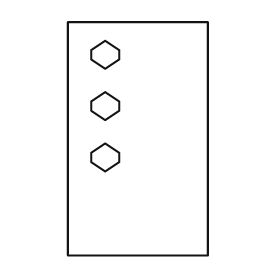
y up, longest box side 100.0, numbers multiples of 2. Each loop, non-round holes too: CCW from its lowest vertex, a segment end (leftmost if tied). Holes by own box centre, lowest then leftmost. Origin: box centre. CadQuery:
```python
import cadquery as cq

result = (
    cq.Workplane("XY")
    .moveTo(-30.0, -50.0)
    .lineTo(30.0, -50.0)
    .lineTo(30.0, 50.0)
    .lineTo(-30.0, 50.0)
    .close()
    .moveTo(-14.0, -14.0)
    .lineTo(-8.0, -10.0)
    .lineTo(-8.0, -6.0)
    .lineTo(-14.0, -2.0)
    .lineTo(-20.0, -6.0)
    .lineTo(-20.0, -10.0)
    .close()
    .moveTo(-14.0, 8.0)
    .lineTo(-8.0, 12.0)
    .lineTo(-8.0, 16.0)
    .lineTo(-14.0, 20.0)
    .lineTo(-20.0, 16.0)
    .lineTo(-20.0, 12.0)
    .close()
    .moveTo(-14.0, 30.0)
    .lineTo(-8.0, 34.0)
    .lineTo(-8.0, 38.0)
    .lineTo(-14.0, 42.0)
    .lineTo(-20.0, 38.0)
    .lineTo(-20.0, 34.0)
    .close()
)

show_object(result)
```